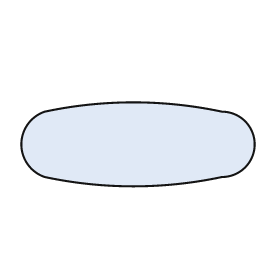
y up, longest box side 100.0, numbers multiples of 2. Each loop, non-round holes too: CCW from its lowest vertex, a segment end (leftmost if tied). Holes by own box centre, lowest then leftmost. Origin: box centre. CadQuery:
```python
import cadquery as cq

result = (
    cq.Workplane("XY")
    .moveTo(-40.0, -14.0)
    .threePointArc((-2.0, -18.0), (36.0, -14.0))
    .threePointArc((50.0, 0.0), (36.0, 14.0))
    .threePointArc((-2.0, 18.0), (-40.0, 14.0))
    .threePointArc((-50.0, 0.0), (-40.0, -14.0))
    .close()
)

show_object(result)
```